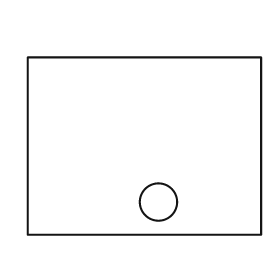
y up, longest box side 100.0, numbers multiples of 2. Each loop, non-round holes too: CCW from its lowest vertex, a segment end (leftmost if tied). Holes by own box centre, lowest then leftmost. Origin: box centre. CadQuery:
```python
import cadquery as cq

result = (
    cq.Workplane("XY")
    .moveTo(-50.0, -38.0)
    .lineTo(50.0, -38.0)
    .lineTo(50.0, 38.0)
    .lineTo(-50.0, 38.0)
    .close()
    .moveTo(6.0, -24.0)
    .circle(8.0)
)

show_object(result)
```